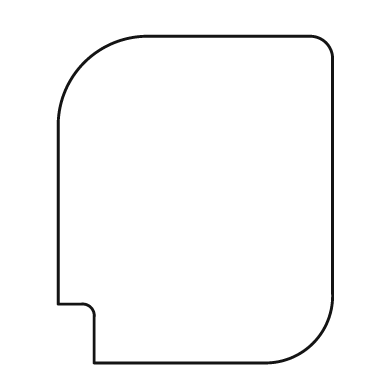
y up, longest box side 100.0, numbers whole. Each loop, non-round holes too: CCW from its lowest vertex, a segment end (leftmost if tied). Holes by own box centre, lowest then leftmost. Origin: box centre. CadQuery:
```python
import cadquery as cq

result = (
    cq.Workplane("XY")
    .moveTo(-31.0, -50.0)
    .lineTo(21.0, -50.0)
    .threePointArc((36.0, -44.0), (42.0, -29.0))
    .lineTo(42.0, 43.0)
    .threePointArc((40.0, 48.0), (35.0, 50.0))
    .lineTo(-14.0, 50.0)
    .threePointArc((-34.0, 42.0), (-42.0, 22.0))
    .lineTo(-42.0, -32.0)
    .lineTo(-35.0, -32.0)
    .threePointArc((-32.0, -33.0), (-31.0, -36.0))
    .close()
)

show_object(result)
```